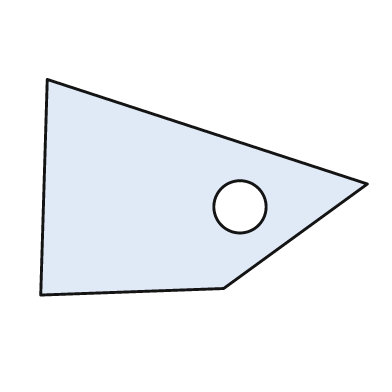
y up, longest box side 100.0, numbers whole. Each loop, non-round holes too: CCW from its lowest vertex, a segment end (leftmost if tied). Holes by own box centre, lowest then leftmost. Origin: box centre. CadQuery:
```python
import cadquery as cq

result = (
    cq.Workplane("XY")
    .moveTo(-50.0, -33.0)
    .lineTo(6.0, -31.0)
    .lineTo(50.0, 1.0)
    .lineTo(-48.0, 33.0)
    .close()
    .moveTo(11.0, -6.0)
    .circle(8.0)
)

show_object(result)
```